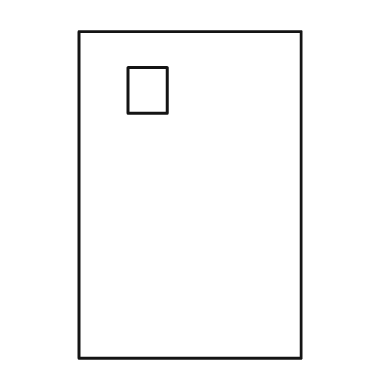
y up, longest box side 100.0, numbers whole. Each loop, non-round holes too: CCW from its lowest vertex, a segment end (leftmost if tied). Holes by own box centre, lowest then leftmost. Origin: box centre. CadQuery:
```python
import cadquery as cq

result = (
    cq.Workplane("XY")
    .moveTo(-34.0, -50.0)
    .lineTo(34.0, -50.0)
    .lineTo(34.0, 50.0)
    .lineTo(-34.0, 50.0)
    .close()
    .moveTo(-19.0, 25.0)
    .lineTo(-7.0, 25.0)
    .lineTo(-7.0, 39.0)
    .lineTo(-19.0, 39.0)
    .close()
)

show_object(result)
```